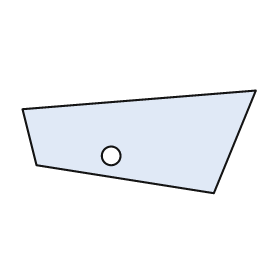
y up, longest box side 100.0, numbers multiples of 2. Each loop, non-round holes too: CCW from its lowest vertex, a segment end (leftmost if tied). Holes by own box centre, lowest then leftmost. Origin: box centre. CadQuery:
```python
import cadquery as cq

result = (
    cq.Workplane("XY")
    .moveTo(32.0, -22.0)
    .lineTo(50.0, 22.0)
    .lineTo(-50.0, 14.0)
    .lineTo(-44.0, -10.0)
    .close()
    .moveTo(-12.0, -6.0)
    .circle(4.0)
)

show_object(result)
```